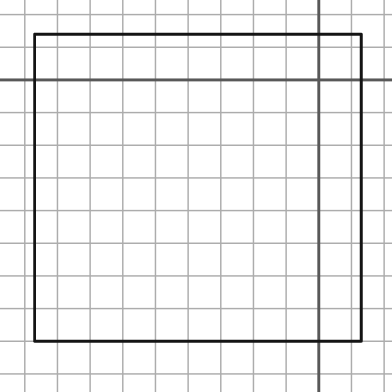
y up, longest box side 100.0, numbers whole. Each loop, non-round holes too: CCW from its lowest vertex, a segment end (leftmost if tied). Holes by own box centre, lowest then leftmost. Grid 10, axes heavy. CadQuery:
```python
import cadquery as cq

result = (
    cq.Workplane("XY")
    .moveTo(-87.0, -80.0)
    .lineTo(13.0, -80.0)
    .lineTo(13.0, 14.0)
    .lineTo(-87.0, 14.0)
    .close()
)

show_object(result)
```